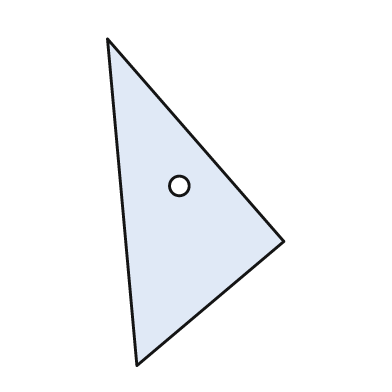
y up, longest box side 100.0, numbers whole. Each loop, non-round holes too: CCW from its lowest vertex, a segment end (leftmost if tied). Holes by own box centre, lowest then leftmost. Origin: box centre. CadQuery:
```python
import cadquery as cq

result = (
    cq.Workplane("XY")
    .moveTo(-18.0, -50.0)
    .lineTo(27.0, -12.0)
    .lineTo(-27.0, 50.0)
    .close()
    .moveTo(-5.0, 5.0)
    .circle(3.0)
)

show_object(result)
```